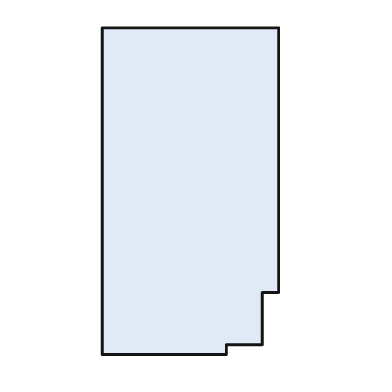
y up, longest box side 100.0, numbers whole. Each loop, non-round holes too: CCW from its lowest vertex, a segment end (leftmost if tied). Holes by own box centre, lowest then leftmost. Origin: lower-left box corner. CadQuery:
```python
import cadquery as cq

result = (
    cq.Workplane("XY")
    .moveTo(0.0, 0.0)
    .lineTo(38.0, 0.0)
    .lineTo(38.0, 3.0)
    .lineTo(49.0, 3.0)
    .lineTo(49.0, 19.0)
    .lineTo(54.0, 19.0)
    .lineTo(54.0, 100.0)
    .lineTo(0.0, 100.0)
    .close()
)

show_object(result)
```